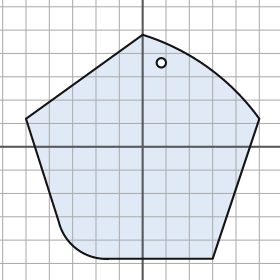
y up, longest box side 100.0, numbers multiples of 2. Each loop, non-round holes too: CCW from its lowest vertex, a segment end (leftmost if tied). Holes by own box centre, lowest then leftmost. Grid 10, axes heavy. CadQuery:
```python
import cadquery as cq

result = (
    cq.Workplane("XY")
    .moveTo(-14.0, -48.0)
    .lineTo(30.0, -48.0)
    .lineTo(50.0, 12.0)
    .threePointArc((28.0, 34.0), (0.0, 48.0))
    .lineTo(-50.0, 12.0)
    .lineTo(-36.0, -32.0)
    .threePointArc((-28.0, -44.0), (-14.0, -48.0))
    .close()
    .moveTo(8.0, 36.0)
    .circle(2.0)
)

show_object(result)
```